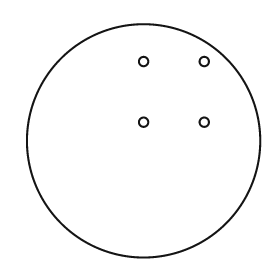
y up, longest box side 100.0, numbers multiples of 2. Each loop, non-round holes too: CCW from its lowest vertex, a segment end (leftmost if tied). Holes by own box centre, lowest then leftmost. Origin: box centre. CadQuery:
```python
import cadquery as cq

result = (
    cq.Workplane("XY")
    .moveTo(0.0, 0.0)
    .circle(50.0)
    .moveTo(0.0, 8.0)
    .circle(2.0)
    .moveTo(26.0, 8.0)
    .circle(2.0)
    .moveTo(0.0, 34.0)
    .circle(2.0)
    .moveTo(26.0, 34.0)
    .circle(2.0)
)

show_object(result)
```